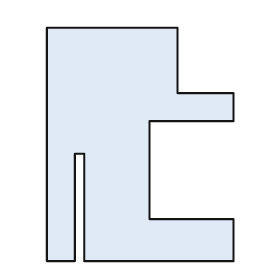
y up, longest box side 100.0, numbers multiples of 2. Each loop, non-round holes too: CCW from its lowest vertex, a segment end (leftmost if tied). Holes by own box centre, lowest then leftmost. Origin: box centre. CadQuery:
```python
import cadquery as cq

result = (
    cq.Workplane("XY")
    .moveTo(-40.0, -50.0)
    .lineTo(-28.0, -50.0)
    .lineTo(-28.0, -4.0)
    .lineTo(-24.0, -4.0)
    .lineTo(-24.0, -50.0)
    .lineTo(40.0, -50.0)
    .lineTo(40.0, -32.0)
    .lineTo(4.0, -32.0)
    .lineTo(4.0, 10.0)
    .lineTo(40.0, 10.0)
    .lineTo(40.0, 22.0)
    .lineTo(16.0, 22.0)
    .lineTo(16.0, 50.0)
    .lineTo(-40.0, 50.0)
    .close()
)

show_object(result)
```